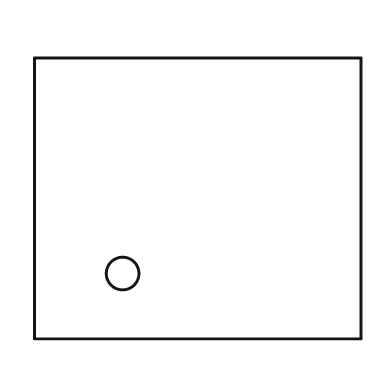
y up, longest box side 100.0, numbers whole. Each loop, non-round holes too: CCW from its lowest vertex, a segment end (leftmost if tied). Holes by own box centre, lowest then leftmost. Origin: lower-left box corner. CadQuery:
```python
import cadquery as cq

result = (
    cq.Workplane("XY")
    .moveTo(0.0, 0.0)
    .lineTo(100.0, 0.0)
    .lineTo(100.0, 86.0)
    .lineTo(0.0, 86.0)
    .close()
    .moveTo(27.0, 20.0)
    .circle(5.0)
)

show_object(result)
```